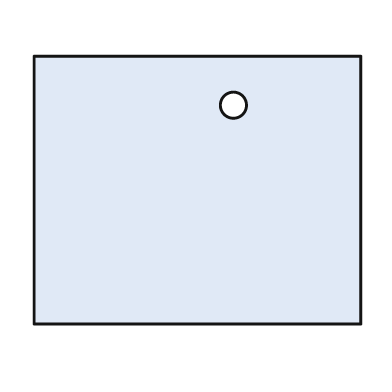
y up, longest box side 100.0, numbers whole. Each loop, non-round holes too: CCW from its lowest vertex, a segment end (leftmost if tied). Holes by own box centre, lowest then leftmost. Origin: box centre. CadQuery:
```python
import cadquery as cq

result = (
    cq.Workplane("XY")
    .moveTo(-50.0, -41.0)
    .lineTo(50.0, -41.0)
    .lineTo(50.0, 41.0)
    .lineTo(-50.0, 41.0)
    .close()
    .moveTo(11.0, 26.0)
    .circle(4.0)
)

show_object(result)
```